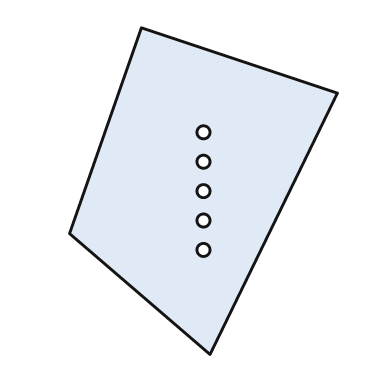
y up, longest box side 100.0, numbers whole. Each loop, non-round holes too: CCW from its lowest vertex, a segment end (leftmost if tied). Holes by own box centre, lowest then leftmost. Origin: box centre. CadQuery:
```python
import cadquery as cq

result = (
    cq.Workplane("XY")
    .moveTo(2.0, -50.0)
    .lineTo(41.0, 30.0)
    .lineTo(-19.0, 50.0)
    .lineTo(-41.0, -13.0)
    .close()
    .moveTo(0.0, -18.0)
    .circle(2.0)
    .moveTo(0.0, -9.0)
    .circle(2.0)
    .moveTo(0.0, 0.0)
    .circle(2.0)
    .moveTo(0.0, 9.0)
    .circle(2.0)
    .moveTo(0.0, 18.0)
    .circle(2.0)
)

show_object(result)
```